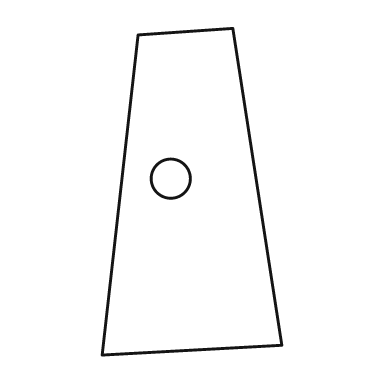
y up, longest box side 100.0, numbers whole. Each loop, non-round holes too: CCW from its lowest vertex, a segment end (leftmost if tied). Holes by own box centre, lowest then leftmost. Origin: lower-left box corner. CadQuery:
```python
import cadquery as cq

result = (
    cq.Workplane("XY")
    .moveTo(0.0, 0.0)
    .lineTo(55.0, 3.0)
    .lineTo(40.0, 100.0)
    .lineTo(11.0, 98.0)
    .close()
    .moveTo(21.0, 54.0)
    .circle(6.0)
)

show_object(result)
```